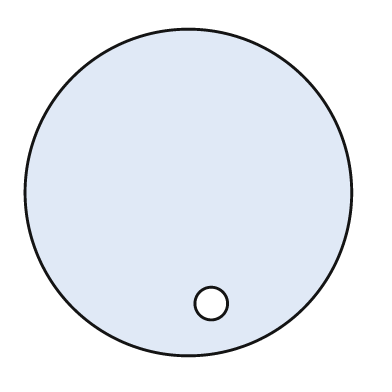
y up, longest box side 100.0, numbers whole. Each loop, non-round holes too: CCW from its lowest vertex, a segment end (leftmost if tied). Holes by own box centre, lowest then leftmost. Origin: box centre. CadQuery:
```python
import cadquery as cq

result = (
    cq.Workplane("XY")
    .moveTo(0.0, 0.0)
    .circle(50.0)
    .moveTo(7.0, -34.0)
    .circle(5.0)
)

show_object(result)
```